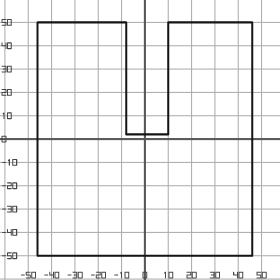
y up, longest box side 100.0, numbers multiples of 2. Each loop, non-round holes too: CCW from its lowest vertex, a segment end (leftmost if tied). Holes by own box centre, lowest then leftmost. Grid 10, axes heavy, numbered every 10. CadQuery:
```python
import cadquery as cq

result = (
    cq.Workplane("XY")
    .moveTo(-46.0, -50.0)
    .lineTo(46.0, -50.0)
    .lineTo(46.0, 50.0)
    .lineTo(10.0, 50.0)
    .lineTo(10.0, 2.0)
    .lineTo(-8.0, 2.0)
    .lineTo(-8.0, 50.0)
    .lineTo(-46.0, 50.0)
    .close()
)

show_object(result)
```